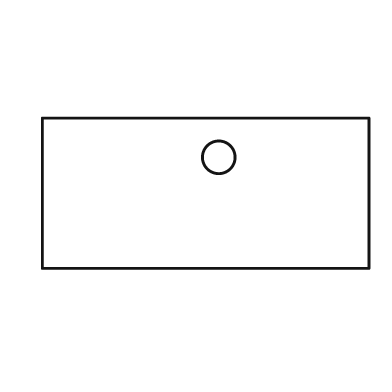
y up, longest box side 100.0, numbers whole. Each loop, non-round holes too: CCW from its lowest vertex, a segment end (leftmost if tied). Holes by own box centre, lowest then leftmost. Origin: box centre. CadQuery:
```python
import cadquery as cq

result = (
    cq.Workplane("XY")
    .moveTo(-50.0, -23.0)
    .lineTo(50.0, -23.0)
    .lineTo(50.0, 23.0)
    .lineTo(-50.0, 23.0)
    .close()
    .moveTo(4.0, 11.0)
    .circle(5.0)
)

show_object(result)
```